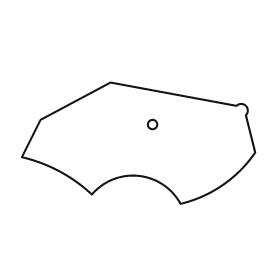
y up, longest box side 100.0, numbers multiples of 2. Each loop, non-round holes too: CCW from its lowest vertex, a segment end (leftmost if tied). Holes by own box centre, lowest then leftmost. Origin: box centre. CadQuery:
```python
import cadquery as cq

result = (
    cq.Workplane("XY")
    .moveTo(18.0, -26.0)
    .threePointArc((36.0, -18.0), (50.0, -4.0))
    .lineTo(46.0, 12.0)
    .threePointArc((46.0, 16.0), (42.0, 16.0))
    .lineTo(-12.0, 26.0)
    .lineTo(-42.0, 10.0)
    .lineTo(-50.0, -6.0)
    .threePointArc((-34.0, -12.0), (-20.0, -22.0))
    .threePointArc((0.0, -14.0), (18.0, -26.0))
    .close()
    .moveTo(6.0, 8.0)
    .circle(2.0)
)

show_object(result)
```